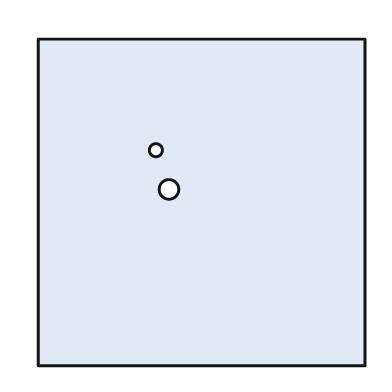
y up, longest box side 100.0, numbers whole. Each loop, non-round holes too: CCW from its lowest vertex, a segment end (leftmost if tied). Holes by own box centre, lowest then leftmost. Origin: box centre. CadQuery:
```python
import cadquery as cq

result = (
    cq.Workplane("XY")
    .moveTo(-50.0, -50.0)
    .lineTo(50.0, -50.0)
    .lineTo(50.0, 50.0)
    .lineTo(-50.0, 50.0)
    .close()
    .moveTo(-10.0, 4.0)
    .circle(3.0)
    .moveTo(-14.0, 16.0)
    .circle(2.0)
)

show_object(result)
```